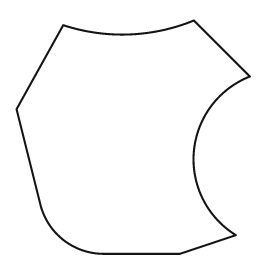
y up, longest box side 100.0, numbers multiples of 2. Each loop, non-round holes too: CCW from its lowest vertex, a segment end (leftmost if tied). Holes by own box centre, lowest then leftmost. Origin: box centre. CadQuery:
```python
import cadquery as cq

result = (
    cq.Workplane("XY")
    .moveTo(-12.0, -50.0)
    .lineTo(20.0, -50.0)
    .lineTo(44.0, -42.0)
    .threePointArc((26.0, -6.0), (50.0, 26.0))
    .lineTo(26.0, 50.0)
    .threePointArc((-2.0, 44.0), (-30.0, 48.0))
    .lineTo(-50.0, 12.0)
    .lineTo(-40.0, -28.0)
    .threePointArc((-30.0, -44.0), (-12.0, -50.0))
    .close()
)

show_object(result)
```